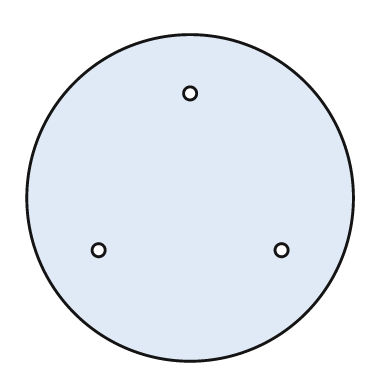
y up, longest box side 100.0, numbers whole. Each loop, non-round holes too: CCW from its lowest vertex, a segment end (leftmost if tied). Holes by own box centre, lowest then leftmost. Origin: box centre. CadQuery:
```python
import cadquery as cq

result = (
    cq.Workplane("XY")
    .moveTo(0.0, 0.0)
    .circle(50.0)
    .moveTo(-28.0, -16.0)
    .circle(2.0)
    .moveTo(28.0, -16.0)
    .circle(2.0)
    .moveTo(0.0, 32.0)
    .circle(2.0)
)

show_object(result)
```